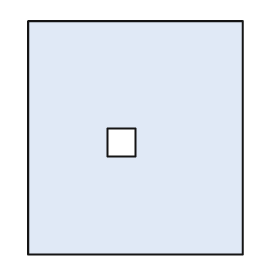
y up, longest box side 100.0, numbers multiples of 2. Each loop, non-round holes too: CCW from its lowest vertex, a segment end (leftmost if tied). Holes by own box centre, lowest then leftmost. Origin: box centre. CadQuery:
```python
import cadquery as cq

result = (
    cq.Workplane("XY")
    .moveTo(-46.0, -50.0)
    .lineTo(46.0, -50.0)
    .lineTo(46.0, 50.0)
    .lineTo(-46.0, 50.0)
    .close()
    .moveTo(-12.0, -8.0)
    .lineTo(0.0, -8.0)
    .lineTo(0.0, 4.0)
    .lineTo(-12.0, 4.0)
    .close()
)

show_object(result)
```